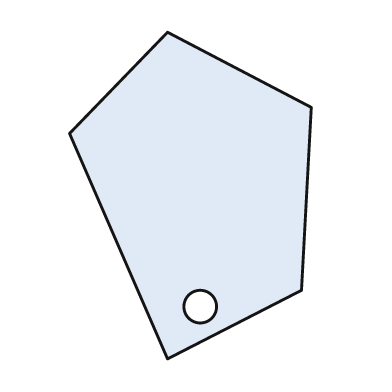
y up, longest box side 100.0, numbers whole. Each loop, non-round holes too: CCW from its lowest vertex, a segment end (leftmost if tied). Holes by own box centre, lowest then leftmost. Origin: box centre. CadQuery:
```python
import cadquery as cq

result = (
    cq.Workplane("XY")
    .moveTo(-7.0, -50.0)
    .lineTo(34.0, -29.0)
    .lineTo(37.0, 27.0)
    .lineTo(-7.0, 50.0)
    .lineTo(-37.0, 19.0)
    .close()
    .moveTo(3.0, -34.0)
    .circle(5.0)
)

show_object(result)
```